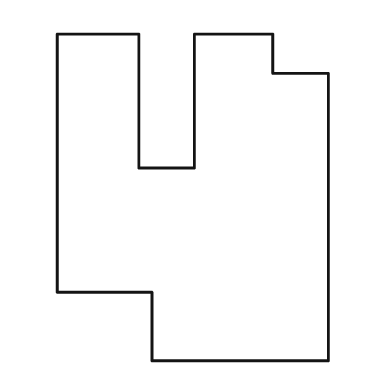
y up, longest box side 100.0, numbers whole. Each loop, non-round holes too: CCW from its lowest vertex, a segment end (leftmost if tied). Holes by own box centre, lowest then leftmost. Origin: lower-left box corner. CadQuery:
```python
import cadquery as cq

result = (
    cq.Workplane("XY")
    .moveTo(29.0, 0.0)
    .lineTo(83.0, 0.0)
    .lineTo(83.0, 88.0)
    .lineTo(66.0, 88.0)
    .lineTo(66.0, 100.0)
    .lineTo(42.0, 100.0)
    .lineTo(42.0, 59.0)
    .lineTo(25.0, 59.0)
    .lineTo(25.0, 100.0)
    .lineTo(0.0, 100.0)
    .lineTo(0.0, 21.0)
    .lineTo(29.0, 21.0)
    .close()
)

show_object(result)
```